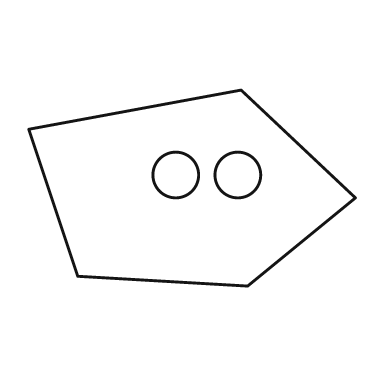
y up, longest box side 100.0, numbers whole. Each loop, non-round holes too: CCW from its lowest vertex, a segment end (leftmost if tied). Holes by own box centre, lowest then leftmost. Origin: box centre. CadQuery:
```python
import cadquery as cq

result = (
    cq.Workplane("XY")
    .moveTo(17.0, -30.0)
    .lineTo(50.0, -3.0)
    .lineTo(15.0, 30.0)
    .lineTo(-50.0, 18.0)
    .lineTo(-35.0, -27.0)
    .close()
    .moveTo(-5.0, 4.0)
    .circle(7.0)
    .moveTo(14.0, 4.0)
    .circle(7.0)
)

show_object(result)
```